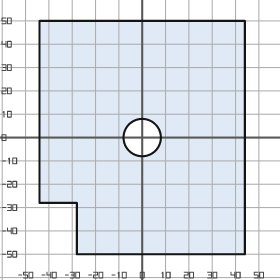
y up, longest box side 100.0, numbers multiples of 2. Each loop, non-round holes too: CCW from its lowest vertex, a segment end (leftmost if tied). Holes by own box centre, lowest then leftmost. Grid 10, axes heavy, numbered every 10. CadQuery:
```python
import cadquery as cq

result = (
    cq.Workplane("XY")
    .moveTo(-28.0, -50.0)
    .lineTo(44.0, -50.0)
    .lineTo(44.0, 50.0)
    .lineTo(-44.0, 50.0)
    .lineTo(-44.0, -28.0)
    .lineTo(-28.0, -28.0)
    .close()
    .moveTo(0.0, 0.0)
    .circle(8.0)
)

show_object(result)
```